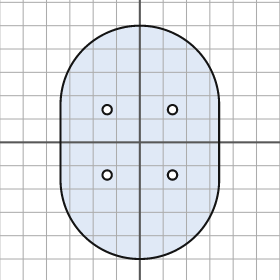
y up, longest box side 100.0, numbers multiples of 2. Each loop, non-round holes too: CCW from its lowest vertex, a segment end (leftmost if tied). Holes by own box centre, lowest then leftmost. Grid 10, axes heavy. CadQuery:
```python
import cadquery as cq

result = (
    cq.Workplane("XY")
    .moveTo(-34.0, -16.0)
    .threePointArc((0.0, -50.0), (34.0, -16.0))
    .lineTo(34.0, 16.0)
    .threePointArc((0.0, 50.0), (-34.0, 16.0))
    .close()
    .moveTo(-14.0, -14.0)
    .circle(2.0)
    .moveTo(14.0, -14.0)
    .circle(2.0)
    .moveTo(-14.0, 14.0)
    .circle(2.0)
    .moveTo(14.0, 14.0)
    .circle(2.0)
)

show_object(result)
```